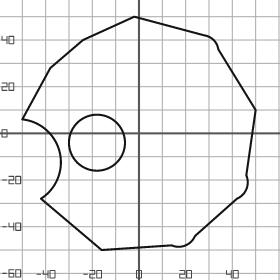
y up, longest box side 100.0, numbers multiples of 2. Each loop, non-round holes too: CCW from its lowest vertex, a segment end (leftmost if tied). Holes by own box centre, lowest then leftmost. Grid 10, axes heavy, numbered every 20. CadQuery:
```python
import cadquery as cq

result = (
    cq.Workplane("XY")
    .moveTo(-16.0, -50.0)
    .lineTo(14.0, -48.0)
    .threePointArc((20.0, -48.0), (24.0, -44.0))
    .lineTo(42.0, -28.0)
    .threePointArc((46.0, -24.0), (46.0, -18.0))
    .lineTo(50.0, 10.0)
    .lineTo(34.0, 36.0)
    .threePointArc((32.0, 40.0), (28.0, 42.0))
    .lineTo(-2.0, 50.0)
    .lineTo(-24.0, 40.0)
    .lineTo(-38.0, 28.0)
    .lineTo(-50.0, 6.0)
    .threePointArc((-34.0, -8.0), (-42.0, -28.0))
    .close()
    .moveTo(-18.0, -4.0)
    .circle(12.0)
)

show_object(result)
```